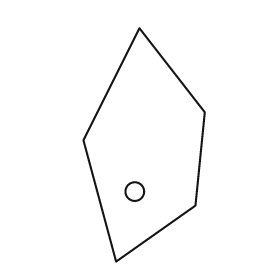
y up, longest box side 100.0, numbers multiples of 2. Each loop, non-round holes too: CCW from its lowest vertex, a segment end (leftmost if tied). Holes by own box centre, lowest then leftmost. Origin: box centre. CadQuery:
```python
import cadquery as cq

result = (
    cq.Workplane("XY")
    .moveTo(-12.0, -50.0)
    .lineTo(22.0, -26.0)
    .lineTo(26.0, 14.0)
    .lineTo(-2.0, 50.0)
    .lineTo(-26.0, 2.0)
    .close()
    .moveTo(-4.0, -20.0)
    .circle(4.0)
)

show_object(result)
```